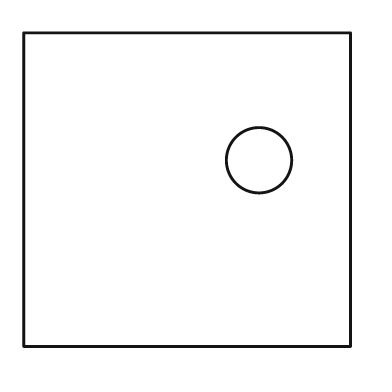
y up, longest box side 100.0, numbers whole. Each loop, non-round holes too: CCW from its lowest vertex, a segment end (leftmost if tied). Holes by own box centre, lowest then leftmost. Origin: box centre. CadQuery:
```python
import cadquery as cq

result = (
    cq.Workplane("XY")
    .moveTo(-50.0, -48.0)
    .lineTo(50.0, -48.0)
    .lineTo(50.0, 48.0)
    .lineTo(-50.0, 48.0)
    .close()
    .moveTo(22.0, 9.0)
    .circle(10.0)
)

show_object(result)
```